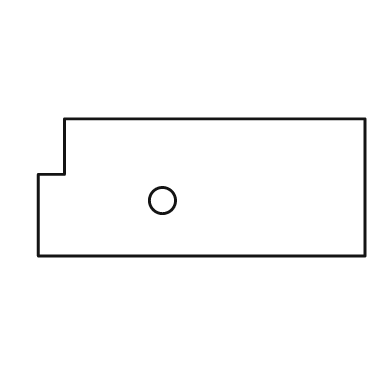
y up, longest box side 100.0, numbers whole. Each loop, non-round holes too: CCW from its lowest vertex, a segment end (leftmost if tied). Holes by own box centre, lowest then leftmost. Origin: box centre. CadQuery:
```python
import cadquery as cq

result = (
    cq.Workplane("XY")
    .moveTo(-50.0, -21.0)
    .lineTo(50.0, -21.0)
    .lineTo(50.0, 21.0)
    .lineTo(-42.0, 21.0)
    .lineTo(-42.0, 4.0)
    .lineTo(-50.0, 4.0)
    .close()
    .moveTo(-12.0, -4.0)
    .circle(4.0)
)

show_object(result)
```